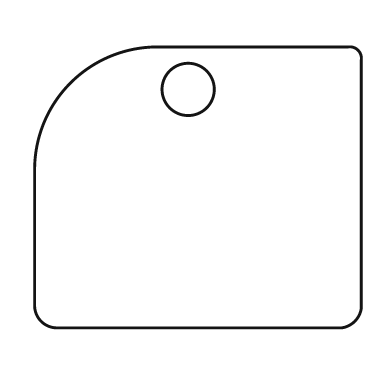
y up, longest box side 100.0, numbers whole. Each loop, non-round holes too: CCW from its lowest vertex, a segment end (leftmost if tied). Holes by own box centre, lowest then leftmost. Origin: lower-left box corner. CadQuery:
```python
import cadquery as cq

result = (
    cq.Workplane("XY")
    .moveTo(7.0, 0.0)
    .lineTo(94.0, 0.0)
    .threePointArc((98.0, 2.0), (100.0, 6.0))
    .lineTo(100.0, 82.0)
    .threePointArc((99.0, 85.0), (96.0, 86.0))
    .lineTo(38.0, 86.0)
    .threePointArc((11.0, 75.0), (0.0, 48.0))
    .lineTo(0.0, 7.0)
    .threePointArc((2.0, 2.0), (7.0, 0.0))
    .close()
    .moveTo(47.0, 73.0)
    .circle(8.0)
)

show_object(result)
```